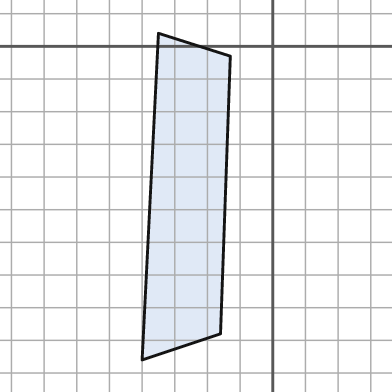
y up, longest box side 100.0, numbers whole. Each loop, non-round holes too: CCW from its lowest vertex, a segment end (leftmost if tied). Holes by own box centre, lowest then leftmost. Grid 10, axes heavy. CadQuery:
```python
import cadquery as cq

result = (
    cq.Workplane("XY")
    .moveTo(-40.0, -96.0)
    .lineTo(-16.0, -88.0)
    .lineTo(-13.0, -3.0)
    .lineTo(-35.0, 4.0)
    .close()
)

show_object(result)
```